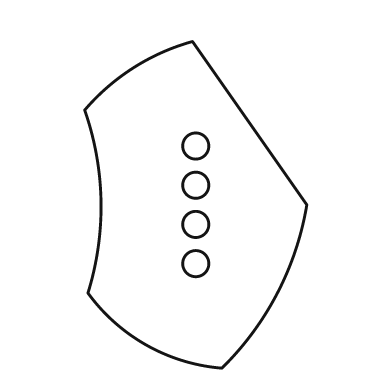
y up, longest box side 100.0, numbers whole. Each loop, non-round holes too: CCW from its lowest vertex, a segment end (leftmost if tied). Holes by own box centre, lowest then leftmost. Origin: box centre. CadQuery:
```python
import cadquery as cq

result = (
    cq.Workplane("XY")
    .moveTo(8.0, -50.0)
    .threePointArc((25.0, -27.0), (34.0, 0.0))
    .lineTo(-1.0, 50.0)
    .threePointArc((-19.0, 42.0), (-34.0, 29.0))
    .threePointArc((-29.0, 1.0), (-33.0, -27.0))
    .threePointArc((-15.0, -43.0), (8.0, -50.0))
    .close()
    .moveTo(0.0, -18.0)
    .circle(4.0)
    .moveTo(0.0, -6.0)
    .circle(4.0)
    .moveTo(0.0, 6.0)
    .circle(4.0)
    .moveTo(0.0, 18.0)
    .circle(4.0)
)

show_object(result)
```